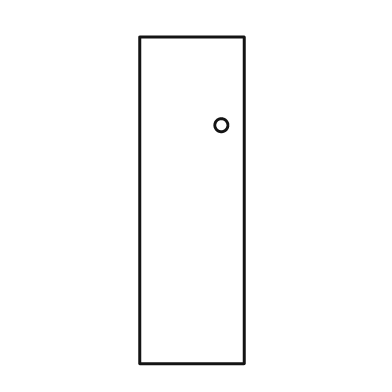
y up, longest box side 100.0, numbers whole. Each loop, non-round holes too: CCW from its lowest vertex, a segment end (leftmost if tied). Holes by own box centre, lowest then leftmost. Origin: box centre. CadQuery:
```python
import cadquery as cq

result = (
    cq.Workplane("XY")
    .moveTo(-16.0, -50.0)
    .lineTo(16.0, -50.0)
    .lineTo(16.0, 50.0)
    .lineTo(-16.0, 50.0)
    .close()
    .moveTo(9.0, 23.0)
    .circle(2.0)
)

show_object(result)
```